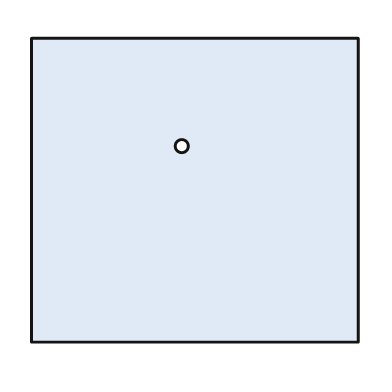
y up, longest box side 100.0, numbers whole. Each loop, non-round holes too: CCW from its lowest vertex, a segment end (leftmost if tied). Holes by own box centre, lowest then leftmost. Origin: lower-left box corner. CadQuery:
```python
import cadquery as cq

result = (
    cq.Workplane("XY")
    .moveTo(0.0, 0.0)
    .lineTo(100.0, 0.0)
    .lineTo(100.0, 93.0)
    .lineTo(0.0, 93.0)
    .close()
    .moveTo(46.0, 60.0)
    .circle(2.0)
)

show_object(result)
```